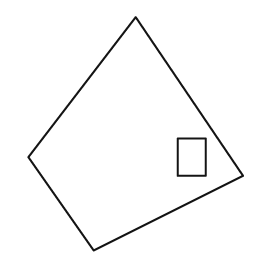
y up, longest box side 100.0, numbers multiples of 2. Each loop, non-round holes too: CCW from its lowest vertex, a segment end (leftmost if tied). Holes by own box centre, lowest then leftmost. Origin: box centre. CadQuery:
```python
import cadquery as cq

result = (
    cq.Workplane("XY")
    .moveTo(-18.0, -50.0)
    .lineTo(46.0, -18.0)
    .lineTo(0.0, 50.0)
    .lineTo(-46.0, -10.0)
    .close()
    .moveTo(18.0, -18.0)
    .lineTo(30.0, -18.0)
    .lineTo(30.0, -2.0)
    .lineTo(18.0, -2.0)
    .close()
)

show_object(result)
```